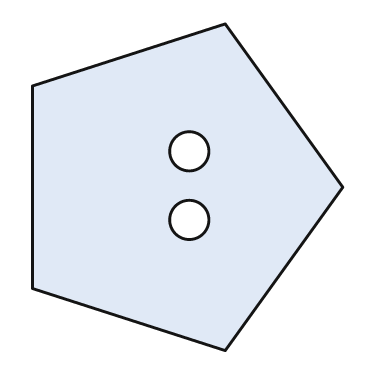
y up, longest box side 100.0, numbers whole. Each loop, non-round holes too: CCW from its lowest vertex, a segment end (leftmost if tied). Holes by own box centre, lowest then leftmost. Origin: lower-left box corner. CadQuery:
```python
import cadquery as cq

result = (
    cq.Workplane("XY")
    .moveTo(59.0, 0.0)
    .lineTo(95.0, 50.0)
    .lineTo(59.0, 100.0)
    .lineTo(0.0, 81.0)
    .lineTo(0.0, 19.0)
    .close()
    .moveTo(48.0, 40.0)
    .circle(6.0)
    .moveTo(48.0, 61.0)
    .circle(6.0)
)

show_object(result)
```